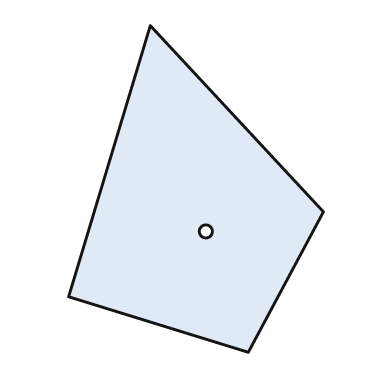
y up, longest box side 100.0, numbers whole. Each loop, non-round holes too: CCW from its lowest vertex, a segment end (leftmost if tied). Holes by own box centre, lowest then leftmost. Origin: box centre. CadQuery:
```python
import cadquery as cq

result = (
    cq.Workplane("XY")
    .moveTo(16.0, -50.0)
    .lineTo(39.0, -7.0)
    .lineTo(-14.0, 50.0)
    .lineTo(-39.0, -33.0)
    .close()
    .moveTo(3.0, -13.0)
    .circle(2.0)
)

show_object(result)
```